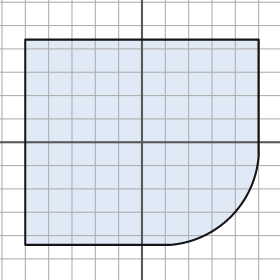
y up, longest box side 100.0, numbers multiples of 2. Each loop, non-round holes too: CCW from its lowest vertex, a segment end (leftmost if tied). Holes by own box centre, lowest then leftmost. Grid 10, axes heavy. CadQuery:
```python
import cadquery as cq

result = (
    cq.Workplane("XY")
    .moveTo(-50.0, -44.0)
    .lineTo(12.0, -44.0)
    .threePointArc((38.0, -32.0), (50.0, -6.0))
    .lineTo(50.0, 44.0)
    .lineTo(-50.0, 44.0)
    .close()
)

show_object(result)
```